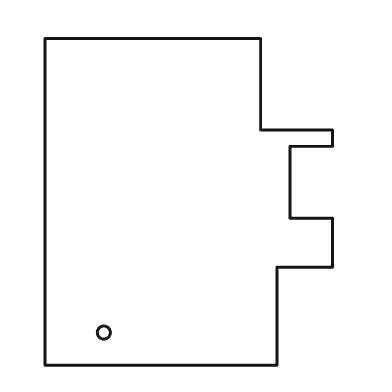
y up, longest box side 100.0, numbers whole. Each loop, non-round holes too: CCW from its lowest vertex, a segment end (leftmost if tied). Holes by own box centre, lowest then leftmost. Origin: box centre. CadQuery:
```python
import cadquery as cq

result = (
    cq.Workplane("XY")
    .moveTo(-44.0, -50.0)
    .lineTo(27.0, -50.0)
    .lineTo(27.0, -20.0)
    .lineTo(44.0, -20.0)
    .lineTo(44.0, -5.0)
    .lineTo(31.0, -5.0)
    .lineTo(31.0, 17.0)
    .lineTo(44.0, 17.0)
    .lineTo(44.0, 22.0)
    .lineTo(22.0, 22.0)
    .lineTo(22.0, 50.0)
    .lineTo(-44.0, 50.0)
    .close()
    .moveTo(-26.0, -40.0)
    .circle(2.0)
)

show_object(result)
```